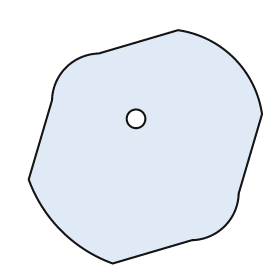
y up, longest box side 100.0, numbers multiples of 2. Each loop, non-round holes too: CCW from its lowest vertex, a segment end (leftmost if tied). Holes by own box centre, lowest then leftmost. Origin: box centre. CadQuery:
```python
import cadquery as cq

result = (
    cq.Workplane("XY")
    .moveTo(-14.0, -50.0)
    .lineTo(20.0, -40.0)
    .threePointArc((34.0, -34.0), (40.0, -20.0))
    .lineTo(50.0, 14.0)
    .threePointArc((38.0, 38.0), (14.0, 50.0))
    .lineTo(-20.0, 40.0)
    .threePointArc((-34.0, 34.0), (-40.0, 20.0))
    .lineTo(-50.0, -14.0)
    .threePointArc((-36.0, -36.0), (-14.0, -50.0))
    .close()
    .moveTo(-4.0, 12.0)
    .circle(4.0)
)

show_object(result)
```